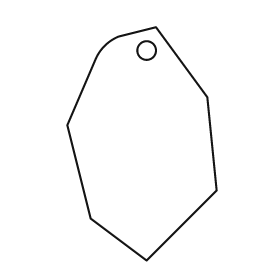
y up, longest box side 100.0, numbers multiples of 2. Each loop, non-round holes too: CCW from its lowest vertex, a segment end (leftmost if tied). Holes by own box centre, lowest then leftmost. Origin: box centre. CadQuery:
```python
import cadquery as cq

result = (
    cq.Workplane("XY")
    .moveTo(2.0, -50.0)
    .lineTo(32.0, -20.0)
    .lineTo(28.0, 20.0)
    .lineTo(6.0, 50.0)
    .lineTo(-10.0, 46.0)
    .threePointArc((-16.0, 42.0), (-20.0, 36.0))
    .lineTo(-32.0, 8.0)
    .lineTo(-22.0, -32.0)
    .close()
    .moveTo(2.0, 40.0)
    .circle(4.0)
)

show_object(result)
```